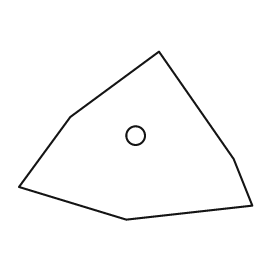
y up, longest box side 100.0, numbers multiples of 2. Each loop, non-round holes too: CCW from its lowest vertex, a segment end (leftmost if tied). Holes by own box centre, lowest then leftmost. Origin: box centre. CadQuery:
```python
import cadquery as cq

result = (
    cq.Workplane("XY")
    .moveTo(-4.0, -36.0)
    .lineTo(50.0, -30.0)
    .lineTo(42.0, -10.0)
    .lineTo(10.0, 36.0)
    .lineTo(-28.0, 8.0)
    .lineTo(-50.0, -22.0)
    .close()
    .moveTo(0.0, 0.0)
    .circle(4.0)
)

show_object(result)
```